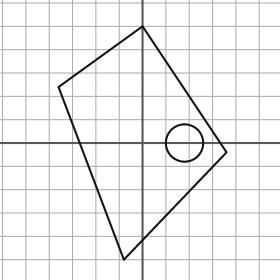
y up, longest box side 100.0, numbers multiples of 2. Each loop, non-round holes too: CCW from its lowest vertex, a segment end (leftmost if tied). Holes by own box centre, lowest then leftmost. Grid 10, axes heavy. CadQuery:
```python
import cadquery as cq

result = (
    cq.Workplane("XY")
    .moveTo(-8.0, -50.0)
    .lineTo(36.0, -4.0)
    .lineTo(0.0, 50.0)
    .lineTo(-36.0, 24.0)
    .close()
    .moveTo(18.0, 0.0)
    .circle(8.0)
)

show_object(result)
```